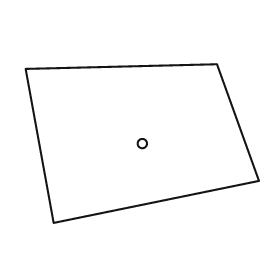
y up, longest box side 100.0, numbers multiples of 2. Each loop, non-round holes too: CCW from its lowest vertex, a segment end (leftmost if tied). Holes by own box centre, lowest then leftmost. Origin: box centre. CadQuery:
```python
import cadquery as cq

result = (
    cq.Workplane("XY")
    .moveTo(-38.0, -34.0)
    .lineTo(50.0, -16.0)
    .lineTo(32.0, 34.0)
    .lineTo(-50.0, 32.0)
    .close()
    .moveTo(0.0, 0.0)
    .circle(2.0)
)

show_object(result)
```